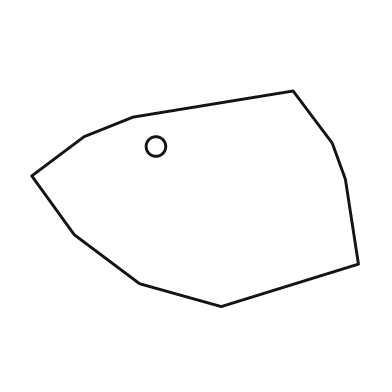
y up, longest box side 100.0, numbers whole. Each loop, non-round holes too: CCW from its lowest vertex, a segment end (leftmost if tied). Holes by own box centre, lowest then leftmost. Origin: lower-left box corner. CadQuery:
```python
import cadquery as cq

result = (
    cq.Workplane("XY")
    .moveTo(58.0, 0.0)
    .lineTo(100.0, 13.0)
    .lineTo(96.0, 39.0)
    .lineTo(92.0, 50.0)
    .lineTo(80.0, 66.0)
    .lineTo(31.0, 58.0)
    .lineTo(16.0, 52.0)
    .lineTo(0.0, 40.0)
    .lineTo(13.0, 22.0)
    .lineTo(33.0, 7.0)
    .close()
    .moveTo(38.0, 49.0)
    .circle(3.0)
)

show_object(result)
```